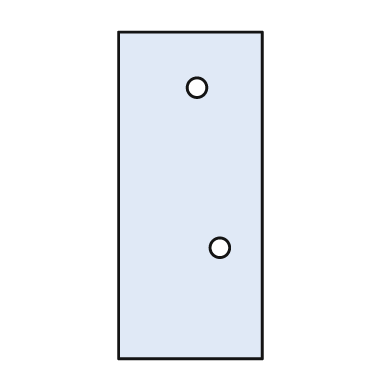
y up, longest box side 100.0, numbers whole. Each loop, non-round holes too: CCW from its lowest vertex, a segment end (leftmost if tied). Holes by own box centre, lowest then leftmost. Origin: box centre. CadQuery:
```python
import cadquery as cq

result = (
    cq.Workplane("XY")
    .moveTo(-22.0, -50.0)
    .lineTo(22.0, -50.0)
    .lineTo(22.0, 50.0)
    .lineTo(-22.0, 50.0)
    .close()
    .moveTo(9.0, -16.0)
    .circle(3.0)
    .moveTo(2.0, 33.0)
    .circle(3.0)
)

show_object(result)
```